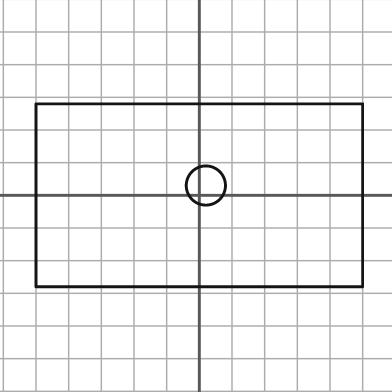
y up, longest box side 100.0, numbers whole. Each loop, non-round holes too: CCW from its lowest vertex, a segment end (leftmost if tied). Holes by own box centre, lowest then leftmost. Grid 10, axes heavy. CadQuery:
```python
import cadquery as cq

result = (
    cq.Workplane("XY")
    .moveTo(-50.0, -28.0)
    .lineTo(50.0, -28.0)
    .lineTo(50.0, 28.0)
    .lineTo(-50.0, 28.0)
    .close()
    .moveTo(2.0, 3.0)
    .circle(6.0)
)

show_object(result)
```